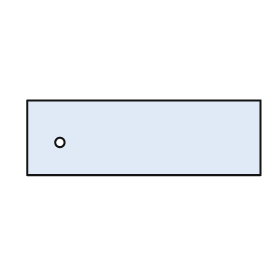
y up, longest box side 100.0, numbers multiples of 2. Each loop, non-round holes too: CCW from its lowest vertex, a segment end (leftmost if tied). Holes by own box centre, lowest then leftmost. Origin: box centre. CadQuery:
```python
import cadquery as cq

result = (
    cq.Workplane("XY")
    .moveTo(-50.0, -16.0)
    .lineTo(50.0, -16.0)
    .lineTo(50.0, 16.0)
    .lineTo(-50.0, 16.0)
    .close()
    .moveTo(-36.0, -2.0)
    .circle(2.0)
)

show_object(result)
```